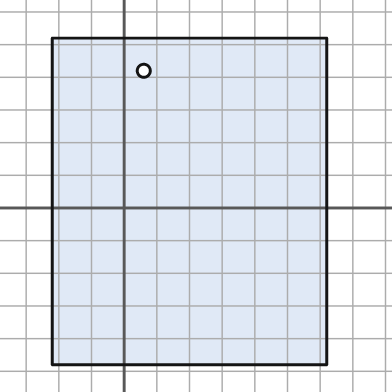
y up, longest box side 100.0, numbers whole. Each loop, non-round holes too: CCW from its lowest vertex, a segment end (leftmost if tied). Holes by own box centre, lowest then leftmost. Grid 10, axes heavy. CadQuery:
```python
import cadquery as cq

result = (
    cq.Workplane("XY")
    .moveTo(-22.0, -48.0)
    .lineTo(62.0, -48.0)
    .lineTo(62.0, 52.0)
    .lineTo(-22.0, 52.0)
    .close()
    .moveTo(6.0, 42.0)
    .circle(2.0)
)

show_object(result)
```